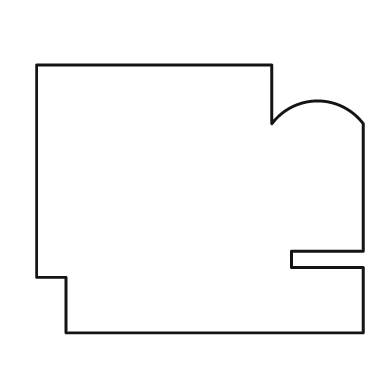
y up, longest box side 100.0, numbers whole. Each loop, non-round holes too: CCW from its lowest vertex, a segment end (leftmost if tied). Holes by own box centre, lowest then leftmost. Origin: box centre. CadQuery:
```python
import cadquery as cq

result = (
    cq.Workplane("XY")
    .moveTo(-41.0, -41.0)
    .lineTo(50.0, -41.0)
    .lineTo(50.0, -21.0)
    .lineTo(28.0, -21.0)
    .lineTo(28.0, -16.0)
    .lineTo(50.0, -16.0)
    .lineTo(50.0, 23.0)
    .threePointArc((36.0, 30.0), (22.0, 23.0))
    .lineTo(22.0, 41.0)
    .lineTo(-50.0, 41.0)
    .lineTo(-50.0, -24.0)
    .lineTo(-41.0, -24.0)
    .close()
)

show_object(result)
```